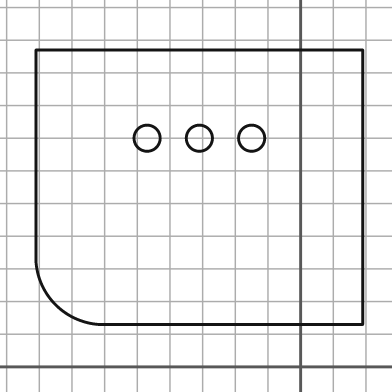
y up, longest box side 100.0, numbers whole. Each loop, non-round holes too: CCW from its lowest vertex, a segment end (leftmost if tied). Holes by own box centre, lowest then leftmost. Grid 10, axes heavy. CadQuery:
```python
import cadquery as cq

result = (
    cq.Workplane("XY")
    .moveTo(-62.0, 13.0)
    .lineTo(19.0, 13.0)
    .lineTo(19.0, 97.0)
    .lineTo(-81.0, 97.0)
    .lineTo(-81.0, 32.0)
    .threePointArc((-75.0, 19.0), (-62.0, 13.0))
    .close()
    .moveTo(-47.0, 70.0)
    .circle(4.0)
    .moveTo(-31.0, 70.0)
    .circle(4.0)
    .moveTo(-15.0, 70.0)
    .circle(4.0)
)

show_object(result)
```